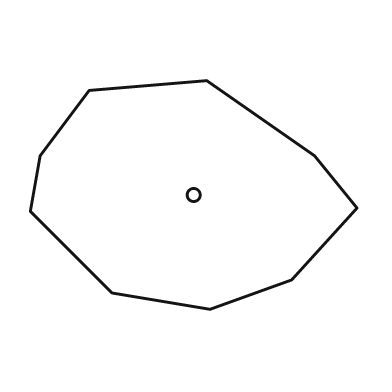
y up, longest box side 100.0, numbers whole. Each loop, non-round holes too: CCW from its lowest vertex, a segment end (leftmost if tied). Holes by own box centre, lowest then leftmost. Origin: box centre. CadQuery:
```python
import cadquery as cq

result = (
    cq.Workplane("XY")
    .moveTo(5.0, -35.0)
    .lineTo(30.0, -26.0)
    .lineTo(50.0, -4.0)
    .lineTo(37.0, 12.0)
    .lineTo(4.0, 35.0)
    .lineTo(-32.0, 32.0)
    .lineTo(-47.0, 12.0)
    .lineTo(-50.0, -5.0)
    .lineTo(-25.0, -30.0)
    .close()
    .moveTo(0.0, 0.0)
    .circle(2.0)
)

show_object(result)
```